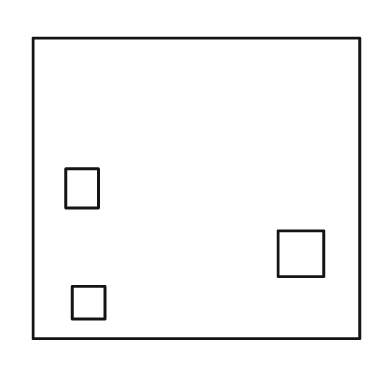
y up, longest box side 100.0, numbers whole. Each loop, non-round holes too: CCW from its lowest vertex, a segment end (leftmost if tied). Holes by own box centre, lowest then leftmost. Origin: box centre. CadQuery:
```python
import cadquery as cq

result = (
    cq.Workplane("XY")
    .moveTo(-50.0, -46.0)
    .lineTo(50.0, -46.0)
    .lineTo(50.0, 46.0)
    .lineTo(-50.0, 46.0)
    .close()
    .moveTo(-38.0, -40.0)
    .lineTo(-28.0, -40.0)
    .lineTo(-28.0, -30.0)
    .lineTo(-38.0, -30.0)
    .close()
    .moveTo(25.0, -27.0)
    .lineTo(39.0, -27.0)
    .lineTo(39.0, -13.0)
    .lineTo(25.0, -13.0)
    .close()
    .moveTo(-40.0, -6.0)
    .lineTo(-30.0, -6.0)
    .lineTo(-30.0, 6.0)
    .lineTo(-40.0, 6.0)
    .close()
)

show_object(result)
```